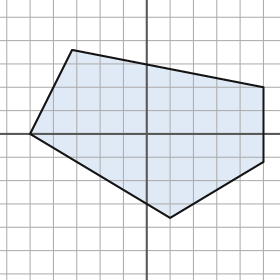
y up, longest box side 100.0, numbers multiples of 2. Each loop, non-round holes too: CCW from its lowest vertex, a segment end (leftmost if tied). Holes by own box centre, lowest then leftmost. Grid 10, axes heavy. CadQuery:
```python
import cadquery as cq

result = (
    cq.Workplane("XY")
    .moveTo(10.0, -36.0)
    .lineTo(50.0, -12.0)
    .lineTo(50.0, 20.0)
    .lineTo(-32.0, 36.0)
    .lineTo(-50.0, 0.0)
    .close()
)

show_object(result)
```